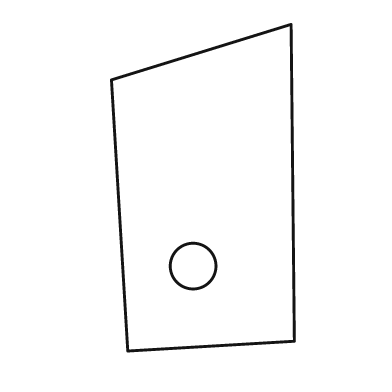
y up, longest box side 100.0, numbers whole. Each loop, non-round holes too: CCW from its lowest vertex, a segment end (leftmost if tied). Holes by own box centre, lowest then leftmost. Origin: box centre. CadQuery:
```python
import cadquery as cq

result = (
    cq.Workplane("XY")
    .moveTo(-23.0, -50.0)
    .lineTo(28.0, -47.0)
    .lineTo(27.0, 50.0)
    .lineTo(-28.0, 33.0)
    .close()
    .moveTo(-3.0, -24.0)
    .circle(7.0)
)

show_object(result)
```